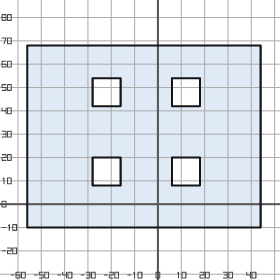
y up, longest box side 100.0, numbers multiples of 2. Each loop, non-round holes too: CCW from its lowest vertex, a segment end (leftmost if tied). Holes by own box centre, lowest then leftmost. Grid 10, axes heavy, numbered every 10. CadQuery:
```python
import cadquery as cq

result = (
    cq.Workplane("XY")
    .moveTo(-56.0, -10.0)
    .lineTo(44.0, -10.0)
    .lineTo(44.0, 68.0)
    .lineTo(-56.0, 68.0)
    .close()
    .moveTo(-28.0, 8.0)
    .lineTo(-16.0, 8.0)
    .lineTo(-16.0, 20.0)
    .lineTo(-28.0, 20.0)
    .close()
    .moveTo(6.0, 8.0)
    .lineTo(18.0, 8.0)
    .lineTo(18.0, 20.0)
    .lineTo(6.0, 20.0)
    .close()
    .moveTo(-28.0, 42.0)
    .lineTo(-16.0, 42.0)
    .lineTo(-16.0, 54.0)
    .lineTo(-28.0, 54.0)
    .close()
    .moveTo(6.0, 42.0)
    .lineTo(18.0, 42.0)
    .lineTo(18.0, 54.0)
    .lineTo(6.0, 54.0)
    .close()
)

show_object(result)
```